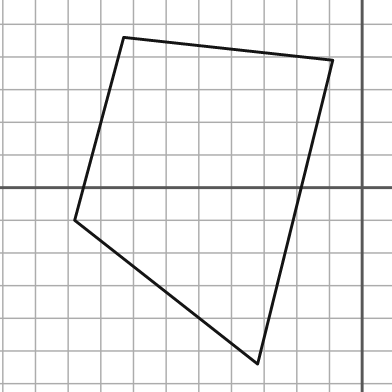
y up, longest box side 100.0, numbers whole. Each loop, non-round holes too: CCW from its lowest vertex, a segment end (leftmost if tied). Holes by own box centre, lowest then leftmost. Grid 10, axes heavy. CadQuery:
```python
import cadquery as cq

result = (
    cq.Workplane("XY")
    .moveTo(-32.0, -54.0)
    .lineTo(-9.0, 39.0)
    .lineTo(-73.0, 46.0)
    .lineTo(-88.0, -10.0)
    .close()
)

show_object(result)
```